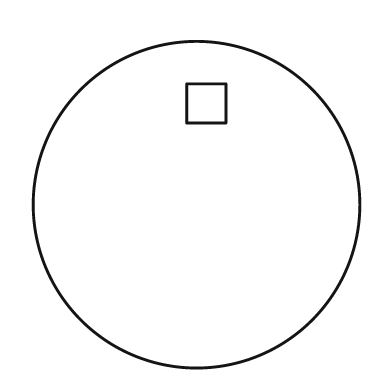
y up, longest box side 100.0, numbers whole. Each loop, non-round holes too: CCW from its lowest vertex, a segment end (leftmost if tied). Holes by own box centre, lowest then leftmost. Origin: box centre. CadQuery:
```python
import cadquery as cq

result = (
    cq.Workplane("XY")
    .moveTo(0.0, 0.0)
    .circle(50.0)
    .moveTo(-3.0, 25.0)
    .lineTo(9.0, 25.0)
    .lineTo(9.0, 37.0)
    .lineTo(-3.0, 37.0)
    .close()
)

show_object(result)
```